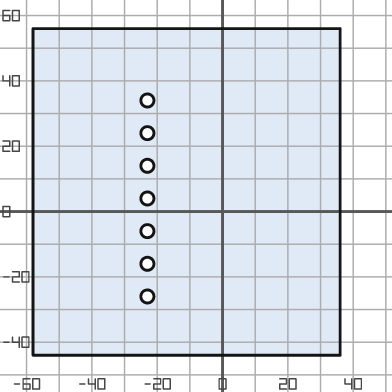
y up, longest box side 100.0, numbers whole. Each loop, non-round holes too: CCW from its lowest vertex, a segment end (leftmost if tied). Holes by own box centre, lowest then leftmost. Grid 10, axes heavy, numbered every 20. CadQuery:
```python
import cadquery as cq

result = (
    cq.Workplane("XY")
    .moveTo(-58.0, -44.0)
    .lineTo(36.0, -44.0)
    .lineTo(36.0, 56.0)
    .lineTo(-58.0, 56.0)
    .close()
    .moveTo(-23.0, -26.0)
    .circle(2.0)
    .moveTo(-23.0, -16.0)
    .circle(2.0)
    .moveTo(-23.0, -6.0)
    .circle(2.0)
    .moveTo(-23.0, 4.0)
    .circle(2.0)
    .moveTo(-23.0, 14.0)
    .circle(2.0)
    .moveTo(-23.0, 24.0)
    .circle(2.0)
    .moveTo(-23.0, 34.0)
    .circle(2.0)
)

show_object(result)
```